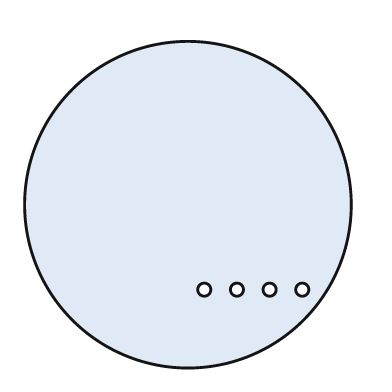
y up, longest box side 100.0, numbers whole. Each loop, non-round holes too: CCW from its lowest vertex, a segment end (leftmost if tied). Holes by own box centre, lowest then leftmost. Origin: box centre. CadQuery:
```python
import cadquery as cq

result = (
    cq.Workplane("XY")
    .moveTo(0.0, 0.0)
    .circle(50.0)
    .moveTo(5.0, -26.0)
    .circle(2.0)
    .moveTo(15.0, -26.0)
    .circle(2.0)
    .moveTo(25.0, -26.0)
    .circle(2.0)
    .moveTo(35.0, -26.0)
    .circle(2.0)
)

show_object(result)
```